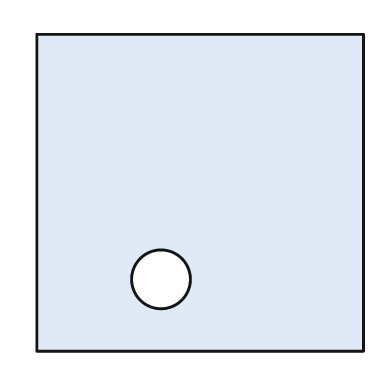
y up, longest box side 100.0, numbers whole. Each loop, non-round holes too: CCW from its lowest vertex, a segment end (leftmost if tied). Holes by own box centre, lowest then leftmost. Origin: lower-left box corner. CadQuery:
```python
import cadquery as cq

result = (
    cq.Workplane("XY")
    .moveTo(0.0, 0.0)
    .lineTo(100.0, 0.0)
    .lineTo(100.0, 97.0)
    .lineTo(0.0, 97.0)
    .close()
    .moveTo(38.0, 22.0)
    .circle(9.0)
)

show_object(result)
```